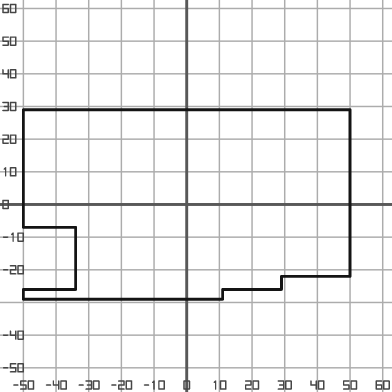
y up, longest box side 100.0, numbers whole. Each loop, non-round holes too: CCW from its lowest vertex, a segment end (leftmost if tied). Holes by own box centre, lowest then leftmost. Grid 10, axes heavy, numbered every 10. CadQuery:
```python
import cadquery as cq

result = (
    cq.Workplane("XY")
    .moveTo(-50.0, -29.0)
    .lineTo(11.0, -29.0)
    .lineTo(11.0, -26.0)
    .lineTo(29.0, -26.0)
    .lineTo(29.0, -22.0)
    .lineTo(50.0, -22.0)
    .lineTo(50.0, 29.0)
    .lineTo(-50.0, 29.0)
    .lineTo(-50.0, -7.0)
    .lineTo(-34.0, -7.0)
    .lineTo(-34.0, -26.0)
    .lineTo(-50.0, -26.0)
    .close()
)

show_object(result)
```